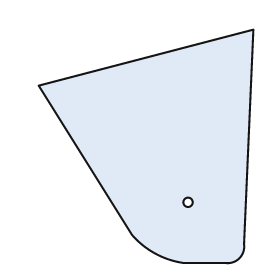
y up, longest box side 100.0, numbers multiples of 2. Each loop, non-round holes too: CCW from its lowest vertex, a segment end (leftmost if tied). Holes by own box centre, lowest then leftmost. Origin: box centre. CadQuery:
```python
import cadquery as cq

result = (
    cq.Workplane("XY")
    .moveTo(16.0, -50.0)
    .lineTo(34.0, -50.0)
    .threePointArc((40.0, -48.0), (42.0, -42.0))
    .lineTo(46.0, 50.0)
    .lineTo(-46.0, 26.0)
    .lineTo(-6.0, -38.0)
    .threePointArc((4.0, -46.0), (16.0, -50.0))
    .close()
    .moveTo(18.0, -24.0)
    .circle(2.0)
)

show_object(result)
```